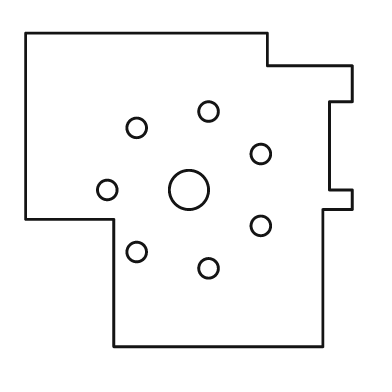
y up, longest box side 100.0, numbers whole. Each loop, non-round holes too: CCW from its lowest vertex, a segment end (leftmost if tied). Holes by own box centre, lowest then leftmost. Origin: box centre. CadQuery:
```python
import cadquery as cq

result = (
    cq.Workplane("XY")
    .moveTo(-23.0, -48.0)
    .lineTo(41.0, -48.0)
    .lineTo(41.0, -6.0)
    .lineTo(50.0, -6.0)
    .lineTo(50.0, 0.0)
    .lineTo(43.0, 0.0)
    .lineTo(43.0, 27.0)
    .lineTo(50.0, 27.0)
    .lineTo(50.0, 38.0)
    .lineTo(24.0, 38.0)
    .lineTo(24.0, 48.0)
    .lineTo(-50.0, 48.0)
    .lineTo(-50.0, -9.0)
    .lineTo(-23.0, -9.0)
    .close()
    .moveTo(6.0, -24.0)
    .circle(3.0)
    .moveTo(-16.0, -19.0)
    .circle(3.0)
    .moveTo(22.0, -11.0)
    .circle(3.0)
    .moveTo(-25.0, 0.0)
    .circle(3.0)
    .moveTo(0.0, 0.0)
    .circle(6.0)
    .moveTo(22.0, 11.0)
    .circle(3.0)
    .moveTo(-16.0, 19.0)
    .circle(3.0)
    .moveTo(6.0, 24.0)
    .circle(3.0)
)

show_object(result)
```